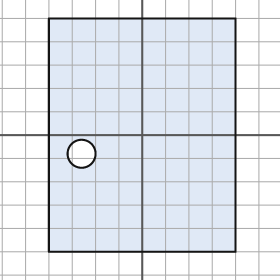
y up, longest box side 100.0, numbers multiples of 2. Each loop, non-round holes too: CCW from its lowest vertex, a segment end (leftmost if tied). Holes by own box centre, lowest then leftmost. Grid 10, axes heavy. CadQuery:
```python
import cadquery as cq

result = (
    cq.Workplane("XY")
    .moveTo(-40.0, -50.0)
    .lineTo(40.0, -50.0)
    .lineTo(40.0, 50.0)
    .lineTo(-40.0, 50.0)
    .close()
    .moveTo(-26.0, -8.0)
    .circle(6.0)
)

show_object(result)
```